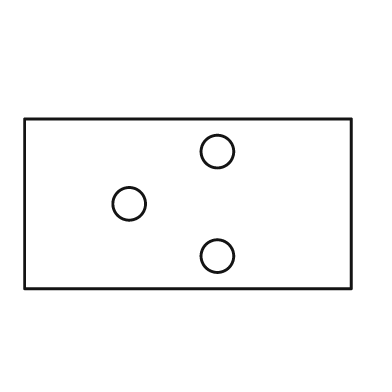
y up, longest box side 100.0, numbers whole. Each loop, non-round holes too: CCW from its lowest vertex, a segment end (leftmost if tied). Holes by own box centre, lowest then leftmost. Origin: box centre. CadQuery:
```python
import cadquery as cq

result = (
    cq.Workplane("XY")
    .moveTo(-50.0, -26.0)
    .lineTo(50.0, -26.0)
    .lineTo(50.0, 26.0)
    .lineTo(-50.0, 26.0)
    .close()
    .moveTo(9.0, -16.0)
    .circle(5.0)
    .moveTo(-18.0, 0.0)
    .circle(5.0)
    .moveTo(9.0, 16.0)
    .circle(5.0)
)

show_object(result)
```